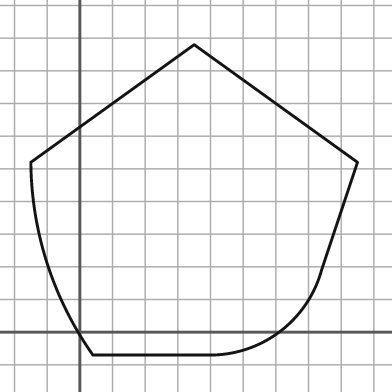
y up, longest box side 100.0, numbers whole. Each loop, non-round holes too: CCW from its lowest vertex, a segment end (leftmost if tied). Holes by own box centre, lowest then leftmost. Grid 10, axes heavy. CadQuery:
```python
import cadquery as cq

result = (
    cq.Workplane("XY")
    .moveTo(4.0, -7.0)
    .lineTo(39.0, -7.0)
    .threePointArc((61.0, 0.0), (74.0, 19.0))
    .lineTo(85.0, 52.0)
    .lineTo(35.0, 88.0)
    .lineTo(-15.0, 52.0)
    .threePointArc((-10.0, 21.0), (4.0, -7.0))
    .close()
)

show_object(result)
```